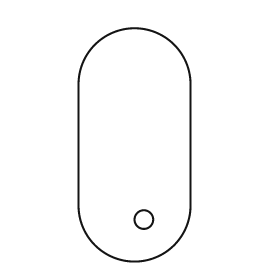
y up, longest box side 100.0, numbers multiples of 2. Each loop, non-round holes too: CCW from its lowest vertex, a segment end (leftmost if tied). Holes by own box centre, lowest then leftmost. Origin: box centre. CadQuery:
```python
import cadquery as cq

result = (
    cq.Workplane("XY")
    .moveTo(-24.0, -26.0)
    .threePointArc((0.0, -50.0), (24.0, -26.0))
    .lineTo(24.0, 26.0)
    .threePointArc((0.0, 50.0), (-24.0, 26.0))
    .close()
    .moveTo(4.0, -32.0)
    .circle(4.0)
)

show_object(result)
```